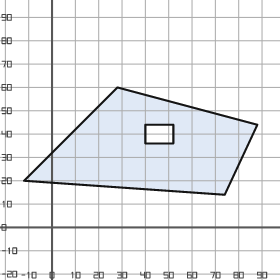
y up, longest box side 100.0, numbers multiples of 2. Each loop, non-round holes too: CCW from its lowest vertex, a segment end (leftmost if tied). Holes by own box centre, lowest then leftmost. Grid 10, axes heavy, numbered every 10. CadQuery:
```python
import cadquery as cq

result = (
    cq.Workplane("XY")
    .moveTo(74.0, 14.0)
    .lineTo(88.0, 44.0)
    .lineTo(28.0, 60.0)
    .lineTo(-12.0, 20.0)
    .close()
    .moveTo(40.0, 36.0)
    .lineTo(52.0, 36.0)
    .lineTo(52.0, 44.0)
    .lineTo(40.0, 44.0)
    .close()
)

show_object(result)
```